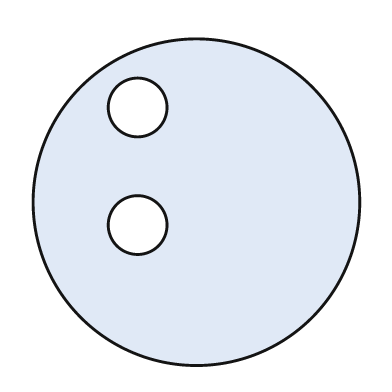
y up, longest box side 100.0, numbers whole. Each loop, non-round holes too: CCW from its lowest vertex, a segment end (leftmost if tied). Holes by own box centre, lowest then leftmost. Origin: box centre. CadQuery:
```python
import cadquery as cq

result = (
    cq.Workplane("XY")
    .moveTo(0.0, 0.0)
    .circle(50.0)
    .moveTo(-18.0, -7.0)
    .circle(9.0)
    .moveTo(-18.0, 29.0)
    .circle(9.0)
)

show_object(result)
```